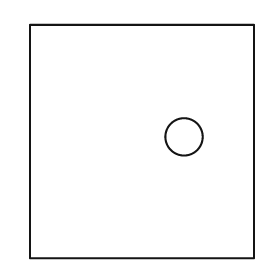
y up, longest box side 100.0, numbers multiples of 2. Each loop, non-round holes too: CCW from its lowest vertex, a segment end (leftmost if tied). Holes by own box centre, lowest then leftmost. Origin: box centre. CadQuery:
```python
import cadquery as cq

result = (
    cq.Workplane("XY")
    .moveTo(-48.0, -50.0)
    .lineTo(48.0, -50.0)
    .lineTo(48.0, 50.0)
    .lineTo(-48.0, 50.0)
    .close()
    .moveTo(18.0, 2.0)
    .circle(8.0)
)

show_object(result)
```